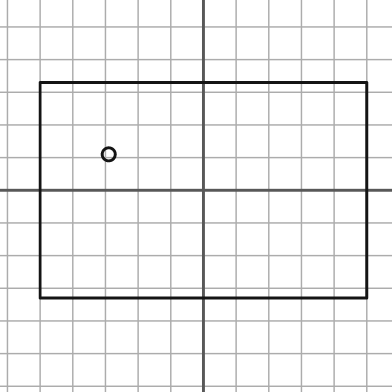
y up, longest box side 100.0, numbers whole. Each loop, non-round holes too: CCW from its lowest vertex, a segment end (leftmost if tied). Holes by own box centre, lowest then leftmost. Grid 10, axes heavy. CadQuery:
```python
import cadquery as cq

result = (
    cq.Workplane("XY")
    .moveTo(-50.0, -33.0)
    .lineTo(50.0, -33.0)
    .lineTo(50.0, 33.0)
    .lineTo(-50.0, 33.0)
    .close()
    .moveTo(-29.0, 11.0)
    .circle(2.0)
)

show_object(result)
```